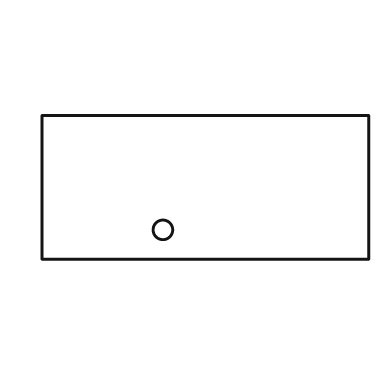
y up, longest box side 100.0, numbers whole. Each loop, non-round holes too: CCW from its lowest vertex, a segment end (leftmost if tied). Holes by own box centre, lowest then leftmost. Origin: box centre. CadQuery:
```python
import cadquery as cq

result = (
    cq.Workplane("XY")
    .moveTo(-50.0, -22.0)
    .lineTo(50.0, -22.0)
    .lineTo(50.0, 22.0)
    .lineTo(-50.0, 22.0)
    .close()
    .moveTo(-13.0, -13.0)
    .circle(3.0)
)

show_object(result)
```